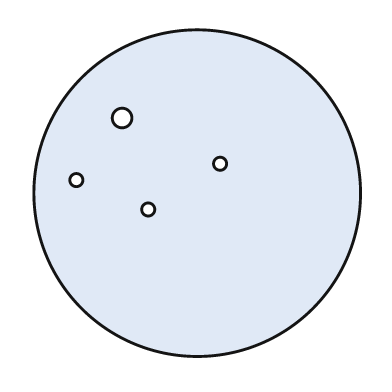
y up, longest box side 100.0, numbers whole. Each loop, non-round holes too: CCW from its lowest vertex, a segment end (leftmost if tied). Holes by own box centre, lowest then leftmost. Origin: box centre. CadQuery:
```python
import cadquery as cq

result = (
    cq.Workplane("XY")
    .moveTo(0.0, 0.0)
    .circle(50.0)
    .moveTo(-15.0, -5.0)
    .circle(2.0)
    .moveTo(-37.0, 4.0)
    .circle(2.0)
    .moveTo(7.0, 9.0)
    .circle(2.0)
    .moveTo(-23.0, 23.0)
    .circle(3.0)
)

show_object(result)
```